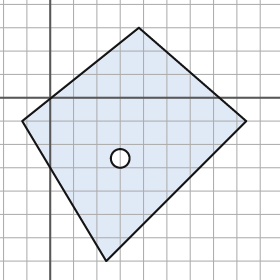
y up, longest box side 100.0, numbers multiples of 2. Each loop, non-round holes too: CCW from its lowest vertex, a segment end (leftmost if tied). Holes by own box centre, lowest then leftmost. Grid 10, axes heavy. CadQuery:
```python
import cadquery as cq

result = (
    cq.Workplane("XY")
    .moveTo(24.0, -70.0)
    .lineTo(84.0, -10.0)
    .lineTo(38.0, 30.0)
    .lineTo(-12.0, -10.0)
    .close()
    .moveTo(30.0, -26.0)
    .circle(4.0)
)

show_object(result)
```